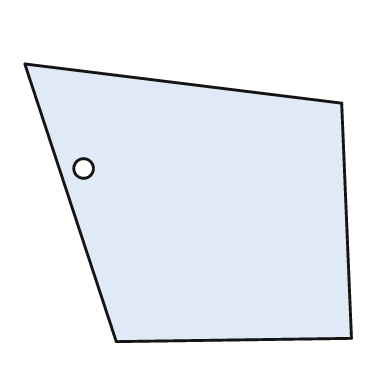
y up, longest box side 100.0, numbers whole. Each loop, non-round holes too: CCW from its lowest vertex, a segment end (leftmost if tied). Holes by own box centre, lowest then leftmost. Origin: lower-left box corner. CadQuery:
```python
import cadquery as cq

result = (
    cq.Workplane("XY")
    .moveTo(28.0, 0.0)
    .lineTo(100.0, 1.0)
    .lineTo(97.0, 73.0)
    .lineTo(0.0, 85.0)
    .close()
    .moveTo(18.0, 53.0)
    .circle(3.0)
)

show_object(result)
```